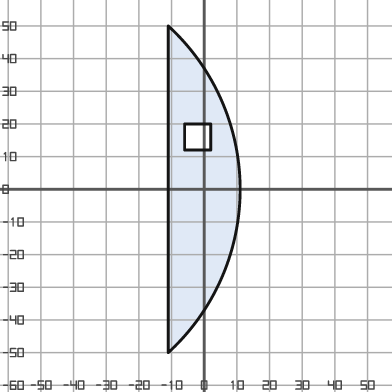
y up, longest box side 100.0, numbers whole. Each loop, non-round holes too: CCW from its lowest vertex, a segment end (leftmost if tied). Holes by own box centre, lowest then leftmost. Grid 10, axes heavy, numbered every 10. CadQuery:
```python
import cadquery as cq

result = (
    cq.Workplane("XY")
    .moveTo(-11.0, -50.0)
    .threePointArc((11.0, 0.0), (-11.0, 50.0))
    .close()
    .moveTo(-6.0, 12.0)
    .lineTo(2.0, 12.0)
    .lineTo(2.0, 20.0)
    .lineTo(-6.0, 20.0)
    .close()
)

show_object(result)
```